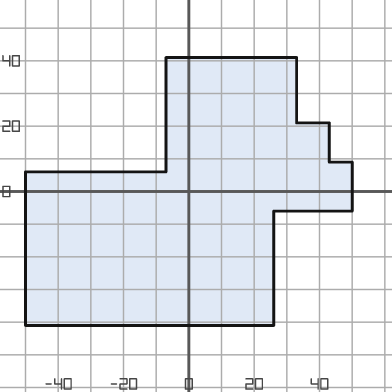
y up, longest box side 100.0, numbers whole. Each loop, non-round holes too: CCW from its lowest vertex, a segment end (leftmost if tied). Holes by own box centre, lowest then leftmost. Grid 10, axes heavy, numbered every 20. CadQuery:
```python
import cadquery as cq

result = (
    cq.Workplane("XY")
    .moveTo(-50.0, -41.0)
    .lineTo(26.0, -41.0)
    .lineTo(26.0, -6.0)
    .lineTo(50.0, -6.0)
    .lineTo(50.0, 9.0)
    .lineTo(43.0, 9.0)
    .lineTo(43.0, 21.0)
    .lineTo(33.0, 21.0)
    .lineTo(33.0, 41.0)
    .lineTo(-7.0, 41.0)
    .lineTo(-7.0, 6.0)
    .lineTo(-50.0, 6.0)
    .close()
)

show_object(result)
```